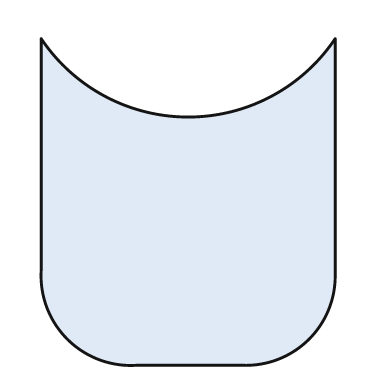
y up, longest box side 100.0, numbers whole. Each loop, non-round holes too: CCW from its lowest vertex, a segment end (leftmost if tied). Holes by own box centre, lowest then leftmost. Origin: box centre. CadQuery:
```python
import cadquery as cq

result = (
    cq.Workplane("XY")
    .moveTo(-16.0, -50.0)
    .lineTo(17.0, -50.0)
    .threePointArc((37.0, -42.0), (45.0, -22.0))
    .lineTo(45.0, 50.0)
    .threePointArc((0.0, 26.0), (-45.0, 50.0))
    .lineTo(-45.0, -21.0)
    .threePointArc((-37.0, -42.0), (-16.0, -50.0))
    .close()
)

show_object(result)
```